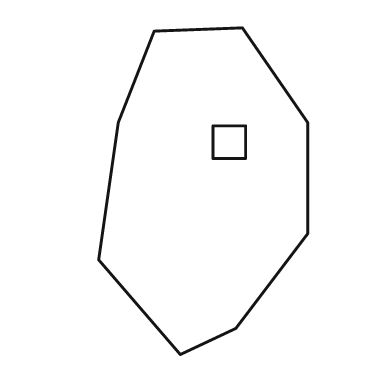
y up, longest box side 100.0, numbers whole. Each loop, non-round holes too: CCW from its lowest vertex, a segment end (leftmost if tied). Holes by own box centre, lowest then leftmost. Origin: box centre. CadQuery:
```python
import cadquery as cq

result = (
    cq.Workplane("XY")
    .moveTo(-7.0, -50.0)
    .lineTo(10.0, -42.0)
    .lineTo(32.0, -13.0)
    .lineTo(32.0, 21.0)
    .lineTo(12.0, 50.0)
    .lineTo(-15.0, 49.0)
    .lineTo(-26.0, 21.0)
    .lineTo(-32.0, -21.0)
    .close()
    .moveTo(3.0, 10.0)
    .lineTo(13.0, 10.0)
    .lineTo(13.0, 20.0)
    .lineTo(3.0, 20.0)
    .close()
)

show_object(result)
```